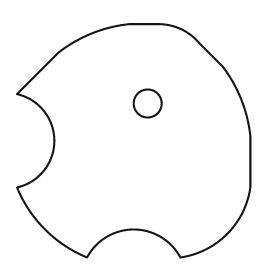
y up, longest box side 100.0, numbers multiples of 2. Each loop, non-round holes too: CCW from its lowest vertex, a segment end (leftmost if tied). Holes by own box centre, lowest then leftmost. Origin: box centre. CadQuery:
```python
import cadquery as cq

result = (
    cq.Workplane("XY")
    .moveTo(-20.0, -50.0)
    .threePointArc((0.0, -38.0), (20.0, -50.0))
    .threePointArc((40.0, -40.0), (50.0, -20.0))
    .lineTo(50.0, 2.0)
    .threePointArc((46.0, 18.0), (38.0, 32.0))
    .lineTo(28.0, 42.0)
    .threePointArc((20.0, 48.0), (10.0, 50.0))
    .lineTo(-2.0, 50.0)
    .threePointArc((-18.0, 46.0), (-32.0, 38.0))
    .lineTo(-50.0, 20.0)
    .threePointArc((-34.0, 0.0), (-50.0, -20.0))
    .threePointArc((-38.0, -38.0), (-20.0, -50.0))
    .close()
    .moveTo(6.0, 16.0)
    .circle(6.0)
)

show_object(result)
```